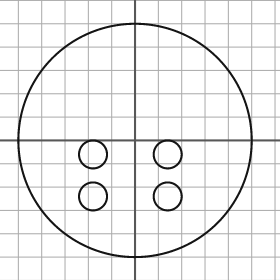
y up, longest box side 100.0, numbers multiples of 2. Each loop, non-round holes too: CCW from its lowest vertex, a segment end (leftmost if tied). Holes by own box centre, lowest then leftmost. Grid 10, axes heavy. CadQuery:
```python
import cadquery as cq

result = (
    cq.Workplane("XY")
    .moveTo(0.0, 0.0)
    .circle(50.0)
    .moveTo(-18.0, -24.0)
    .circle(6.0)
    .moveTo(14.0, -24.0)
    .circle(6.0)
    .moveTo(-18.0, -6.0)
    .circle(6.0)
    .moveTo(14.0, -6.0)
    .circle(6.0)
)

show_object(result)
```